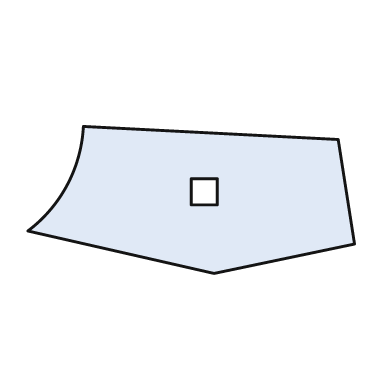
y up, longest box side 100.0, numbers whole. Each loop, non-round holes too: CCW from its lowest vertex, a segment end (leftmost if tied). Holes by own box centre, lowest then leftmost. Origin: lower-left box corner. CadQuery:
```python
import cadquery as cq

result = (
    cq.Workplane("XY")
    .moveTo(57.0, 0.0)
    .lineTo(100.0, 9.0)
    .lineTo(95.0, 41.0)
    .lineTo(17.0, 45.0)
    .threePointArc((12.0, 27.0), (0.0, 13.0))
    .close()
    .moveTo(50.0, 21.0)
    .lineTo(58.0, 21.0)
    .lineTo(58.0, 29.0)
    .lineTo(50.0, 29.0)
    .close()
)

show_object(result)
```